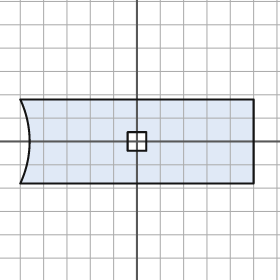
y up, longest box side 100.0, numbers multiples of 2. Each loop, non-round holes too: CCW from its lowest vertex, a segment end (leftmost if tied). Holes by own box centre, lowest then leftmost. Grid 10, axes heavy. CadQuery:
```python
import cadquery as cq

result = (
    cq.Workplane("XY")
    .moveTo(-50.0, -18.0)
    .lineTo(50.0, -18.0)
    .lineTo(50.0, 18.0)
    .lineTo(-50.0, 18.0)
    .threePointArc((-46.0, 0.0), (-50.0, -18.0))
    .close()
    .moveTo(-4.0, -4.0)
    .lineTo(4.0, -4.0)
    .lineTo(4.0, 4.0)
    .lineTo(-4.0, 4.0)
    .close()
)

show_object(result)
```